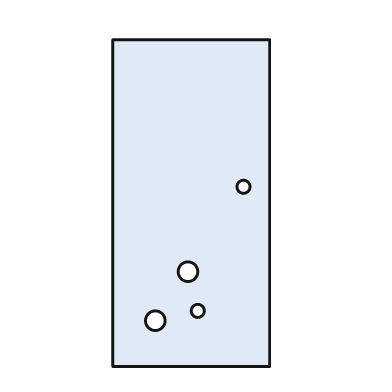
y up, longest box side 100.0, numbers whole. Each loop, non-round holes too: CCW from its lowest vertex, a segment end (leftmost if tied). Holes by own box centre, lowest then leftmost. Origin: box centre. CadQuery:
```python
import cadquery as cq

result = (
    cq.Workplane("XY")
    .moveTo(-24.0, -50.0)
    .lineTo(24.0, -50.0)
    .lineTo(24.0, 50.0)
    .lineTo(-24.0, 50.0)
    .close()
    .moveTo(-11.0, -36.0)
    .circle(3.0)
    .moveTo(2.0, -33.0)
    .circle(2.0)
    .moveTo(-1.0, -21.0)
    .circle(3.0)
    .moveTo(16.0, 5.0)
    .circle(2.0)
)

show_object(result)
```